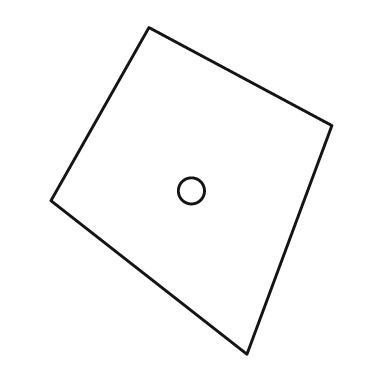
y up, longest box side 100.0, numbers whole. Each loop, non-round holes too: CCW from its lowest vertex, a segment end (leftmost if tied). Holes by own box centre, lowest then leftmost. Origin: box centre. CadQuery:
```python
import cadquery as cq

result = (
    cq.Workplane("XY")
    .moveTo(17.0, -50.0)
    .lineTo(43.0, 20.0)
    .lineTo(-13.0, 50.0)
    .lineTo(-43.0, -3.0)
    .close()
    .moveTo(0.0, 0.0)
    .circle(4.0)
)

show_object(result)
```